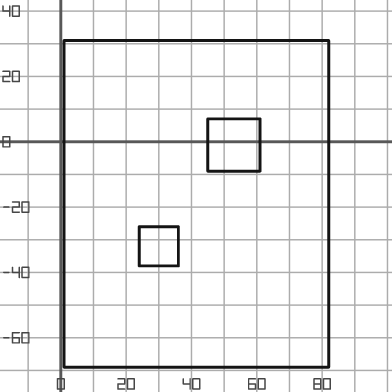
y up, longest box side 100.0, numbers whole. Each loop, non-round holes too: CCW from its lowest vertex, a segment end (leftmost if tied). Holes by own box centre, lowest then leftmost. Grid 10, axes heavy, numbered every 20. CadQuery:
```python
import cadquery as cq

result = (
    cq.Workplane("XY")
    .moveTo(1.0, -69.0)
    .lineTo(82.0, -69.0)
    .lineTo(82.0, 31.0)
    .lineTo(1.0, 31.0)
    .close()
    .moveTo(24.0, -38.0)
    .lineTo(36.0, -38.0)
    .lineTo(36.0, -26.0)
    .lineTo(24.0, -26.0)
    .close()
    .moveTo(45.0, -9.0)
    .lineTo(61.0, -9.0)
    .lineTo(61.0, 7.0)
    .lineTo(45.0, 7.0)
    .close()
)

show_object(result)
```